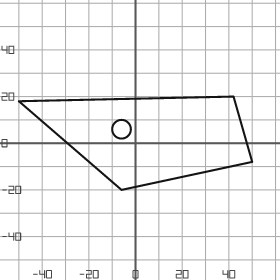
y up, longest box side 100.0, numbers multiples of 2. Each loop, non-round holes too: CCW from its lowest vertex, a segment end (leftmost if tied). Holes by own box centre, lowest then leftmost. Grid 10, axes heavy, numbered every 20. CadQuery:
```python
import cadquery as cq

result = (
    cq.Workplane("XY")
    .moveTo(-6.0, -20.0)
    .lineTo(50.0, -8.0)
    .lineTo(42.0, 20.0)
    .lineTo(-50.0, 18.0)
    .close()
    .moveTo(-6.0, 6.0)
    .circle(4.0)
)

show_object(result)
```